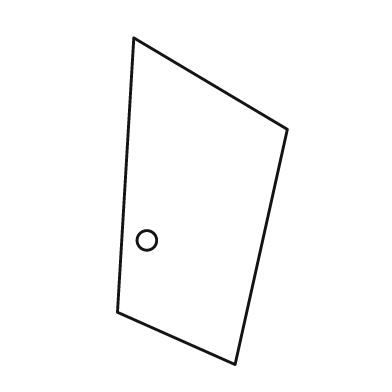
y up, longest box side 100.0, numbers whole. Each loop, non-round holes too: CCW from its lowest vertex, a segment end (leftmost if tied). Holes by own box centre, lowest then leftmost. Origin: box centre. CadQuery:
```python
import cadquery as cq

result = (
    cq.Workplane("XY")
    .moveTo(10.0, -50.0)
    .lineTo(26.0, 22.0)
    .lineTo(-21.0, 50.0)
    .lineTo(-26.0, -34.0)
    .close()
    .moveTo(-17.0, -12.0)
    .circle(3.0)
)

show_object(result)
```